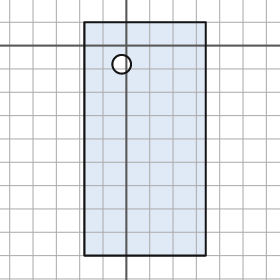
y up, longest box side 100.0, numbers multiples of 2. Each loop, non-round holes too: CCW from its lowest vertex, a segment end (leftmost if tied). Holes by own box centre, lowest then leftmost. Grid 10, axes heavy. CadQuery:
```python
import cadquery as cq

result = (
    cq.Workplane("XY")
    .moveTo(-18.0, -90.0)
    .lineTo(34.0, -90.0)
    .lineTo(34.0, 10.0)
    .lineTo(-18.0, 10.0)
    .close()
    .moveTo(-2.0, -8.0)
    .circle(4.0)
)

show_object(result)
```